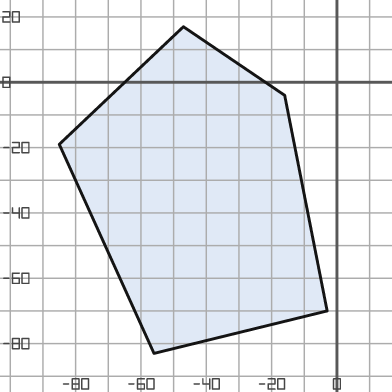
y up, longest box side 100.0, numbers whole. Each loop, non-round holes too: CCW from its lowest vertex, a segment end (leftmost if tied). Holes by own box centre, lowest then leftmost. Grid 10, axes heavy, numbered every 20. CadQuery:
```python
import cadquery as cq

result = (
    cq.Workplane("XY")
    .moveTo(-56.0, -83.0)
    .lineTo(-3.0, -70.0)
    .lineTo(-16.0, -4.0)
    .lineTo(-47.0, 17.0)
    .lineTo(-85.0, -19.0)
    .close()
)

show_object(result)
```